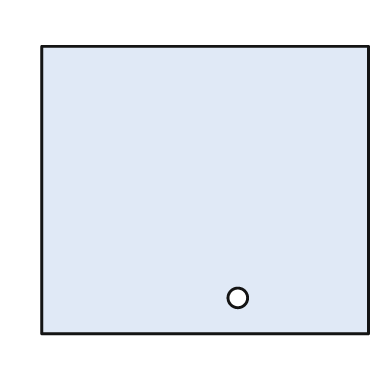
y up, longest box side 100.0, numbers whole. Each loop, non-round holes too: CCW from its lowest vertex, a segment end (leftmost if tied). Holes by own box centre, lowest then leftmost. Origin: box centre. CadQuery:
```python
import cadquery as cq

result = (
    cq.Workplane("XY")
    .moveTo(-50.0, -44.0)
    .lineTo(50.0, -44.0)
    .lineTo(50.0, 44.0)
    .lineTo(-50.0, 44.0)
    .close()
    .moveTo(10.0, -33.0)
    .circle(3.0)
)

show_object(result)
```